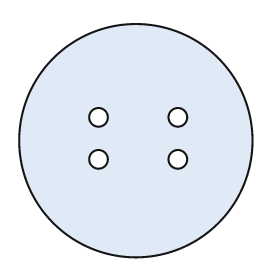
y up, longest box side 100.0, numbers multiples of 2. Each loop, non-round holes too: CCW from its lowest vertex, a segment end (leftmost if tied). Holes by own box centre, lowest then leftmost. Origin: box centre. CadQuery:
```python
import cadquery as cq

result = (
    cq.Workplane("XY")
    .moveTo(0.0, 0.0)
    .circle(50.0)
    .moveTo(-16.0, -8.0)
    .circle(4.0)
    .moveTo(18.0, -8.0)
    .circle(4.0)
    .moveTo(-16.0, 10.0)
    .circle(4.0)
    .moveTo(18.0, 10.0)
    .circle(4.0)
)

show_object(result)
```